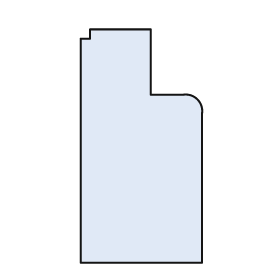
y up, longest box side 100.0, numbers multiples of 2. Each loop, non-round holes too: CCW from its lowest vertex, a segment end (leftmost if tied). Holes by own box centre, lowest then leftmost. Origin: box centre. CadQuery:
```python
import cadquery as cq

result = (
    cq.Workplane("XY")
    .moveTo(-26.0, -50.0)
    .lineTo(26.0, -50.0)
    .lineTo(26.0, 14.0)
    .threePointArc((24.0, 20.0), (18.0, 22.0))
    .lineTo(4.0, 22.0)
    .lineTo(4.0, 50.0)
    .lineTo(-22.0, 50.0)
    .lineTo(-22.0, 46.0)
    .lineTo(-26.0, 46.0)
    .close()
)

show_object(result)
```